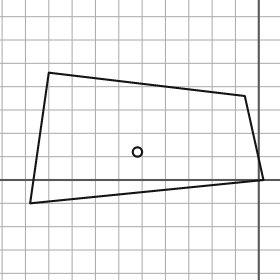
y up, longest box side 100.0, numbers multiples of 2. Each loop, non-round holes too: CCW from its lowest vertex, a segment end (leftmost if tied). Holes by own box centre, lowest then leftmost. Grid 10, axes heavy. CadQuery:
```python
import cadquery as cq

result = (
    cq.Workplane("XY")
    .moveTo(-98.0, -10.0)
    .lineTo(2.0, 0.0)
    .lineTo(-6.0, 36.0)
    .lineTo(-90.0, 46.0)
    .close()
    .moveTo(-52.0, 12.0)
    .circle(2.0)
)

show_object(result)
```